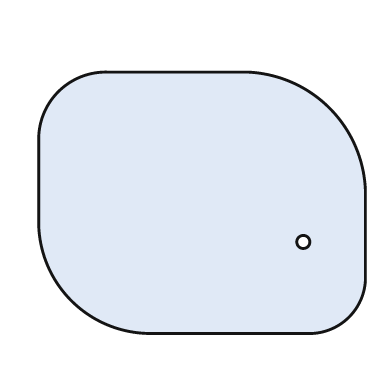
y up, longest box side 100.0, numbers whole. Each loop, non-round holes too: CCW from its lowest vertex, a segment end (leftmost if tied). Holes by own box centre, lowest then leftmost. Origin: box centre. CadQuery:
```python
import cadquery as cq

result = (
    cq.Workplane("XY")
    .moveTo(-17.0, -40.0)
    .lineTo(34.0, -40.0)
    .threePointArc((45.0, -35.0), (50.0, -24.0))
    .lineTo(50.0, 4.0)
    .threePointArc((39.0, 29.0), (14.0, 40.0))
    .lineTo(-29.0, 40.0)
    .threePointArc((-44.0, 34.0), (-50.0, 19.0))
    .lineTo(-50.0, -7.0)
    .threePointArc((-40.0, -30.0), (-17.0, -40.0))
    .close()
    .moveTo(31.0, -12.0)
    .circle(2.0)
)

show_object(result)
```